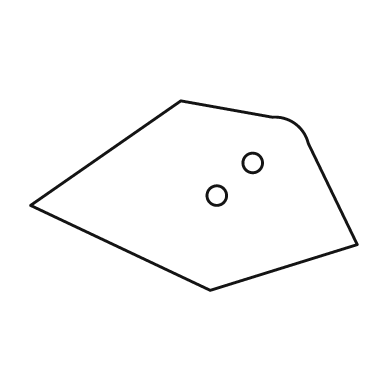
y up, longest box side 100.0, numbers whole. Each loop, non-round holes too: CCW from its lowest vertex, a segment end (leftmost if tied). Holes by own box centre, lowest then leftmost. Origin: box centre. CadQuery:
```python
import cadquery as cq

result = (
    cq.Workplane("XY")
    .moveTo(5.0, -29.0)
    .lineTo(50.0, -15.0)
    .lineTo(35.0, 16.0)
    .threePointArc((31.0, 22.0), (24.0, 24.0))
    .lineTo(-4.0, 29.0)
    .lineTo(-50.0, -3.0)
    .close()
    .moveTo(7.0, 0.0)
    .circle(3.0)
    .moveTo(18.0, 10.0)
    .circle(3.0)
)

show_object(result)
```